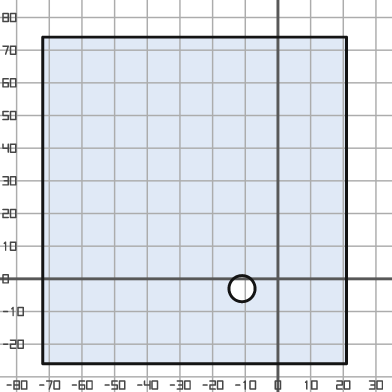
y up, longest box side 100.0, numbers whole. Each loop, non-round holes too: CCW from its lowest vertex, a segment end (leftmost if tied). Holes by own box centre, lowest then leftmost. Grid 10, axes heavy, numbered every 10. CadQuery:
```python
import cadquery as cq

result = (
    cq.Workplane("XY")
    .moveTo(-72.0, -26.0)
    .lineTo(21.0, -26.0)
    .lineTo(21.0, 74.0)
    .lineTo(-72.0, 74.0)
    .close()
    .moveTo(-11.0, -3.0)
    .circle(4.0)
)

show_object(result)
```